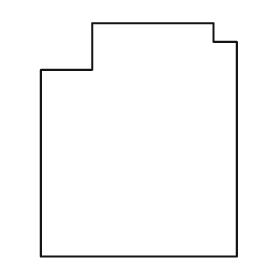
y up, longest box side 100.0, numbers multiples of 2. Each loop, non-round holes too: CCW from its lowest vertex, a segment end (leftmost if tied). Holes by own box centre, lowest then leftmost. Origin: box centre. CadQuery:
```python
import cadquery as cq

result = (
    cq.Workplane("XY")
    .moveTo(-42.0, -50.0)
    .lineTo(42.0, -50.0)
    .lineTo(42.0, 42.0)
    .lineTo(32.0, 42.0)
    .lineTo(32.0, 50.0)
    .lineTo(-20.0, 50.0)
    .lineTo(-20.0, 30.0)
    .lineTo(-42.0, 30.0)
    .close()
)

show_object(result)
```